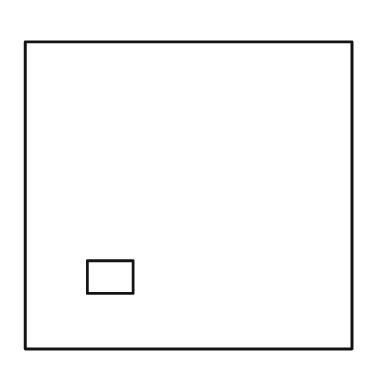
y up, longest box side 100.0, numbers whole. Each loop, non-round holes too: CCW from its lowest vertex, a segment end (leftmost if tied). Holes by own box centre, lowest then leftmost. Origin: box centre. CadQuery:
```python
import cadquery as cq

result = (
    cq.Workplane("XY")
    .moveTo(-50.0, -47.0)
    .lineTo(50.0, -47.0)
    .lineTo(50.0, 47.0)
    .lineTo(-50.0, 47.0)
    .close()
    .moveTo(-31.0, -30.0)
    .lineTo(-17.0, -30.0)
    .lineTo(-17.0, -20.0)
    .lineTo(-31.0, -20.0)
    .close()
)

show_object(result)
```